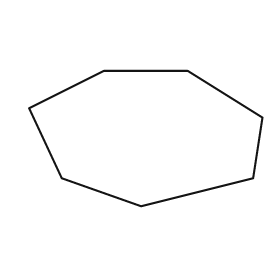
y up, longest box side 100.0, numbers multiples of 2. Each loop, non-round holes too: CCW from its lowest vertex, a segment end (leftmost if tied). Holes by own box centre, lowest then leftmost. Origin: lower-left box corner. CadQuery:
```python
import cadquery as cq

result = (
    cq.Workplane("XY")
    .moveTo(48.0, 0.0)
    .lineTo(96.0, 12.0)
    .lineTo(100.0, 38.0)
    .lineTo(68.0, 58.0)
    .lineTo(32.0, 58.0)
    .lineTo(0.0, 42.0)
    .lineTo(14.0, 12.0)
    .close()
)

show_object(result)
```